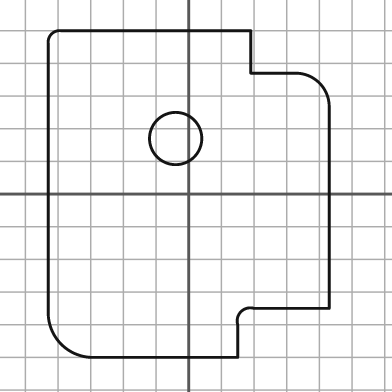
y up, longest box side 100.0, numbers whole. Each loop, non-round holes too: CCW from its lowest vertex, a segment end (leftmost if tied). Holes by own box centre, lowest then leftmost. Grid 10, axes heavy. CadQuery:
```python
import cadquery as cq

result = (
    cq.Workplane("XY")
    .moveTo(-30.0, -50.0)
    .lineTo(15.0, -50.0)
    .lineTo(15.0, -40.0)
    .threePointArc((16.0, -36.0), (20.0, -35.0))
    .lineTo(43.0, -35.0)
    .lineTo(43.0, 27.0)
    .threePointArc((40.0, 34.0), (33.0, 37.0))
    .lineTo(19.0, 37.0)
    .lineTo(19.0, 50.0)
    .lineTo(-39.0, 50.0)
    .threePointArc((-42.0, 49.0), (-43.0, 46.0))
    .lineTo(-43.0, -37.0)
    .threePointArc((-39.0, -46.0), (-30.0, -50.0))
    .close()
    .moveTo(-4.0, 17.0)
    .circle(8.0)
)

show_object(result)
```